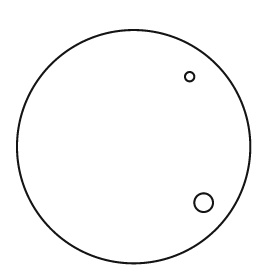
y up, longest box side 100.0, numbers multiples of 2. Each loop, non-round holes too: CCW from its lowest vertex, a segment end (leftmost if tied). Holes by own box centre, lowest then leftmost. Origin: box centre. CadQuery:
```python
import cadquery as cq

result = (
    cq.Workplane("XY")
    .moveTo(0.0, 0.0)
    .circle(50.0)
    .moveTo(30.0, -24.0)
    .circle(4.0)
    .moveTo(24.0, 30.0)
    .circle(2.0)
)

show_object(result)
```